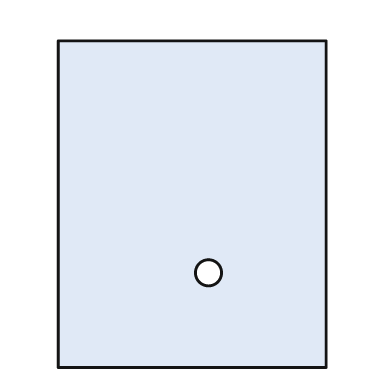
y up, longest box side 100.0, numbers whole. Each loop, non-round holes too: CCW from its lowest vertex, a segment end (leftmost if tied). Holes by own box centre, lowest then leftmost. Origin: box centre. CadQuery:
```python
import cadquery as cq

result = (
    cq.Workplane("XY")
    .moveTo(-41.0, -50.0)
    .lineTo(41.0, -50.0)
    .lineTo(41.0, 50.0)
    .lineTo(-41.0, 50.0)
    .close()
    .moveTo(5.0, -21.0)
    .circle(4.0)
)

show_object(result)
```